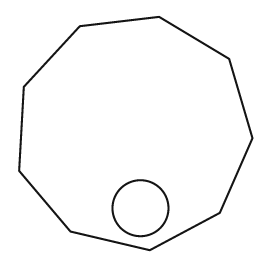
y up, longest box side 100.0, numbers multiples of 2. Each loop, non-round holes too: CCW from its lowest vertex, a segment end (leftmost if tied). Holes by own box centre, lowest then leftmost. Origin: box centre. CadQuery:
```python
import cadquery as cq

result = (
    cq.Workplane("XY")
    .moveTo(6.0, -50.0)
    .lineTo(36.0, -34.0)
    .lineTo(50.0, -2.0)
    .lineTo(40.0, 32.0)
    .lineTo(10.0, 50.0)
    .lineTo(-24.0, 46.0)
    .lineTo(-48.0, 20.0)
    .lineTo(-50.0, -16.0)
    .lineTo(-28.0, -42.0)
    .close()
    .moveTo(2.0, -32.0)
    .circle(12.0)
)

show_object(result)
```